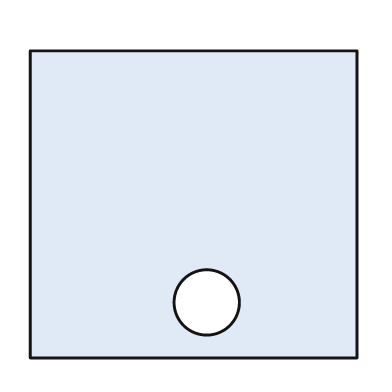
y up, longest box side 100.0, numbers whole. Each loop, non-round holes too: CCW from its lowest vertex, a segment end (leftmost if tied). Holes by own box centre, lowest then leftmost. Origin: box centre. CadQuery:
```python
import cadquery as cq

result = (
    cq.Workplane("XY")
    .moveTo(-50.0, -47.0)
    .lineTo(50.0, -47.0)
    .lineTo(50.0, 47.0)
    .lineTo(-50.0, 47.0)
    .close()
    .moveTo(4.0, -30.0)
    .circle(10.0)
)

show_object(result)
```